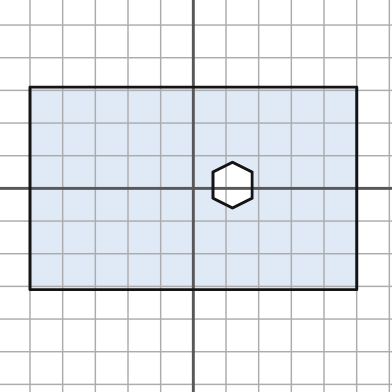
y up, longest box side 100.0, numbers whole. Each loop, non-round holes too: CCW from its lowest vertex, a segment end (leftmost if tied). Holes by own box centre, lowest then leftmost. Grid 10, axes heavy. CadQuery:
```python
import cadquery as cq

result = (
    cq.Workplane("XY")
    .moveTo(-50.0, -31.0)
    .lineTo(50.0, -31.0)
    .lineTo(50.0, 31.0)
    .lineTo(-50.0, 31.0)
    .close()
    .moveTo(12.0, -6.0)
    .lineTo(18.0, -3.0)
    .lineTo(18.0, 5.0)
    .lineTo(12.0, 8.0)
    .lineTo(6.0, 5.0)
    .lineTo(6.0, -3.0)
    .close()
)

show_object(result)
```